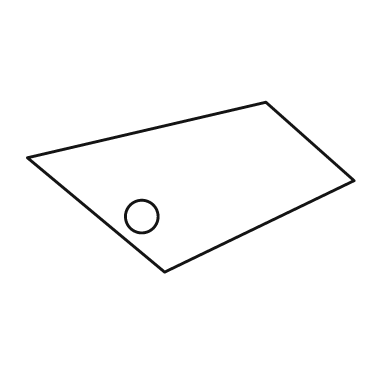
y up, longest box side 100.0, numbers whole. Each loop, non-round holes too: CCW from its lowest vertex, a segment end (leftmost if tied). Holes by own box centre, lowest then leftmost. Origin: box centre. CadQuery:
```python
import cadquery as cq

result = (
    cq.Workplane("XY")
    .moveTo(-8.0, -26.0)
    .lineTo(50.0, 2.0)
    .lineTo(23.0, 26.0)
    .lineTo(-50.0, 9.0)
    .close()
    .moveTo(-15.0, -9.0)
    .circle(5.0)
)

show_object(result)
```